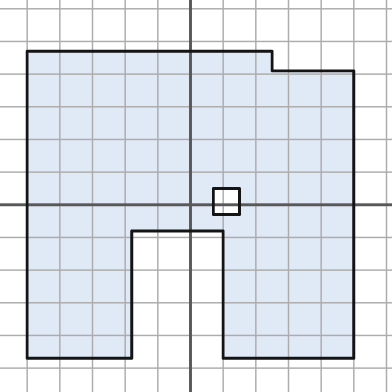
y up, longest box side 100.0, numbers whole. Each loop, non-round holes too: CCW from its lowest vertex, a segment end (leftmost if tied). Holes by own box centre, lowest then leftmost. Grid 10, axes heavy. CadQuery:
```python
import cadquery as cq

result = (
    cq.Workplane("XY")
    .moveTo(-50.0, -47.0)
    .lineTo(-18.0, -47.0)
    .lineTo(-18.0, -8.0)
    .lineTo(10.0, -8.0)
    .lineTo(10.0, -47.0)
    .lineTo(50.0, -47.0)
    .lineTo(50.0, 41.0)
    .lineTo(25.0, 41.0)
    .lineTo(25.0, 47.0)
    .lineTo(-50.0, 47.0)
    .close()
    .moveTo(7.0, -3.0)
    .lineTo(15.0, -3.0)
    .lineTo(15.0, 5.0)
    .lineTo(7.0, 5.0)
    .close()
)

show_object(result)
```